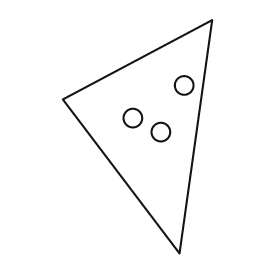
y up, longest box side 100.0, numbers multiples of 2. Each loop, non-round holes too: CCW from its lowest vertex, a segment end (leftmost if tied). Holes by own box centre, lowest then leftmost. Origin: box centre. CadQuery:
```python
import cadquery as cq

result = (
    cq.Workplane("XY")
    .moveTo(18.0, -50.0)
    .lineTo(32.0, 50.0)
    .lineTo(-32.0, 16.0)
    .close()
    .moveTo(10.0, 2.0)
    .circle(4.0)
    .moveTo(-2.0, 8.0)
    .circle(4.0)
    .moveTo(20.0, 22.0)
    .circle(4.0)
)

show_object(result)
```